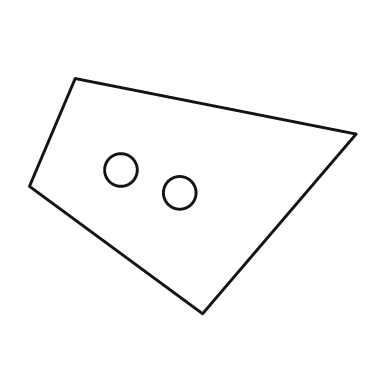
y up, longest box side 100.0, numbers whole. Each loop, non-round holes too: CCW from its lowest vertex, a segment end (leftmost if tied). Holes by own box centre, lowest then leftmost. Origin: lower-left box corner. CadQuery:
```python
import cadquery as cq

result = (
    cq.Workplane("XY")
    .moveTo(53.0, 0.0)
    .lineTo(100.0, 55.0)
    .lineTo(14.0, 72.0)
    .lineTo(0.0, 39.0)
    .close()
    .moveTo(46.0, 37.0)
    .circle(5.0)
    .moveTo(28.0, 44.0)
    .circle(5.0)
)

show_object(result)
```